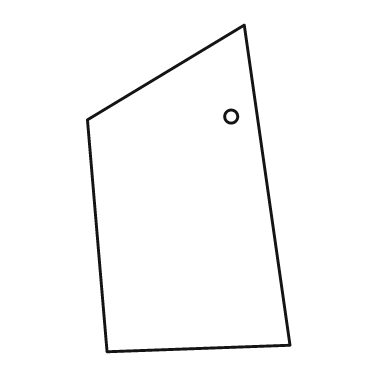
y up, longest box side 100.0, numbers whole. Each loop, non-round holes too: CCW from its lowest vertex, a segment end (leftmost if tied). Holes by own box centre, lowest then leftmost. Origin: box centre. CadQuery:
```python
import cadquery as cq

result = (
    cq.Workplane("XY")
    .moveTo(-25.0, -50.0)
    .lineTo(31.0, -48.0)
    .lineTo(17.0, 50.0)
    .lineTo(-31.0, 21.0)
    .close()
    .moveTo(13.0, 22.0)
    .circle(2.0)
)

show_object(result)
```